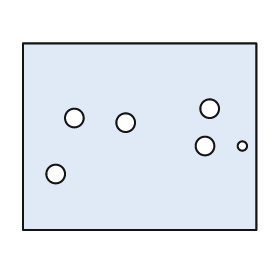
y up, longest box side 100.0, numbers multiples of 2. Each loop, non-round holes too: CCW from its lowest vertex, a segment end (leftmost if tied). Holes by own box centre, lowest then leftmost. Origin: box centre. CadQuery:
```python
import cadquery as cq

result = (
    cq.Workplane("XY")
    .moveTo(-50.0, -40.0)
    .lineTo(50.0, -40.0)
    .lineTo(50.0, 40.0)
    .lineTo(-50.0, 40.0)
    .close()
    .moveTo(-36.0, -16.0)
    .circle(4.0)
    .moveTo(28.0, -4.0)
    .circle(4.0)
    .moveTo(44.0, -4.0)
    .circle(2.0)
    .moveTo(-6.0, 6.0)
    .circle(4.0)
    .moveTo(-28.0, 8.0)
    .circle(4.0)
    .moveTo(30.0, 12.0)
    .circle(4.0)
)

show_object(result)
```